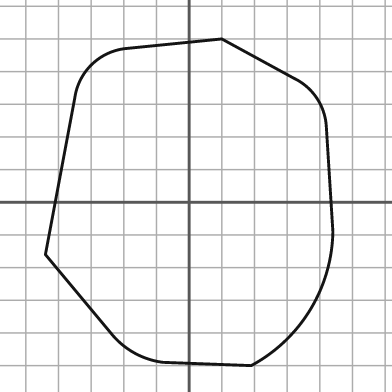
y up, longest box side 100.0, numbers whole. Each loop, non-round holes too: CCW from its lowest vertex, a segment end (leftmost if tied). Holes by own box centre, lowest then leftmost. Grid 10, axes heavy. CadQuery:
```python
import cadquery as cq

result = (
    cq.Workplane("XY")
    .moveTo(19.0, -50.0)
    .threePointArc((37.0, -33.0), (44.0, -9.0))
    .lineTo(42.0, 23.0)
    .threePointArc((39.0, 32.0), (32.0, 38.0))
    .lineTo(10.0, 50.0)
    .lineTo(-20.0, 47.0)
    .threePointArc((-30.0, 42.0), (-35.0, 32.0))
    .lineTo(-44.0, -16.0)
    .lineTo(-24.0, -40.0)
    .threePointArc((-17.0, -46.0), (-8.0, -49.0))
    .close()
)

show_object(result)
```